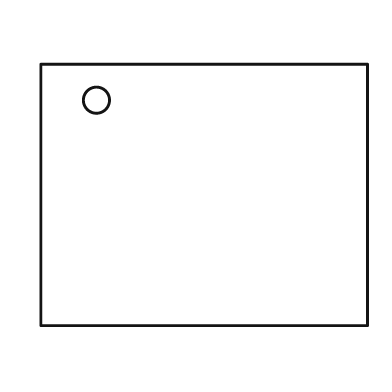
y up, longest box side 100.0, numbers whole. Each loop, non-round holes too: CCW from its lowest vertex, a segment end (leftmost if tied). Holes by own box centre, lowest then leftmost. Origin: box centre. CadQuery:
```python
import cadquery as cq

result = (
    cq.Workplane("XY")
    .moveTo(-50.0, -40.0)
    .lineTo(50.0, -40.0)
    .lineTo(50.0, 40.0)
    .lineTo(-50.0, 40.0)
    .close()
    .moveTo(-33.0, 29.0)
    .circle(4.0)
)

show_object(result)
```